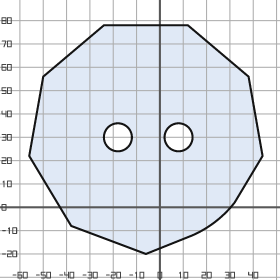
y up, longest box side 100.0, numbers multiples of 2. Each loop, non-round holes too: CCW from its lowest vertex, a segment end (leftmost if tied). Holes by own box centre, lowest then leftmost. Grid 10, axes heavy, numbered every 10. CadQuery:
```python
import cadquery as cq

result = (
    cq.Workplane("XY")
    .moveTo(-6.0, -20.0)
    .lineTo(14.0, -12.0)
    .threePointArc((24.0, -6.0), (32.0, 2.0))
    .lineTo(44.0, 22.0)
    .lineTo(38.0, 56.0)
    .lineTo(12.0, 78.0)
    .lineTo(-24.0, 78.0)
    .lineTo(-50.0, 56.0)
    .lineTo(-56.0, 22.0)
    .lineTo(-38.0, -8.0)
    .close()
    .moveTo(-18.0, 30.0)
    .circle(6.0)
    .moveTo(8.0, 30.0)
    .circle(6.0)
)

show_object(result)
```